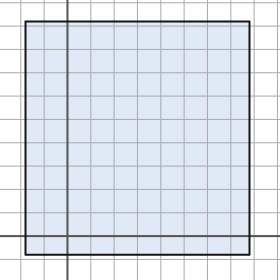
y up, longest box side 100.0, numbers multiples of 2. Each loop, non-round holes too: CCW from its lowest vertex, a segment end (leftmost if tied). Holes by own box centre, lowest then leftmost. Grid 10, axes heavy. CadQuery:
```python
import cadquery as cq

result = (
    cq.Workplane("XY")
    .moveTo(-18.0, -8.0)
    .lineTo(78.0, -8.0)
    .lineTo(78.0, 92.0)
    .lineTo(-18.0, 92.0)
    .close()
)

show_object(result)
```